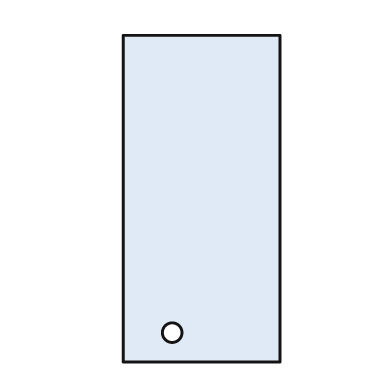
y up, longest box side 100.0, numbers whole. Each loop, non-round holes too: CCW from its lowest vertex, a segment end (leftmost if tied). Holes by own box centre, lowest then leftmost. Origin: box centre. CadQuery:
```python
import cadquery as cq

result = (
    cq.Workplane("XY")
    .moveTo(-24.0, -50.0)
    .lineTo(24.0, -50.0)
    .lineTo(24.0, 50.0)
    .lineTo(-24.0, 50.0)
    .close()
    .moveTo(-9.0, -41.0)
    .circle(3.0)
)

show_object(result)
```